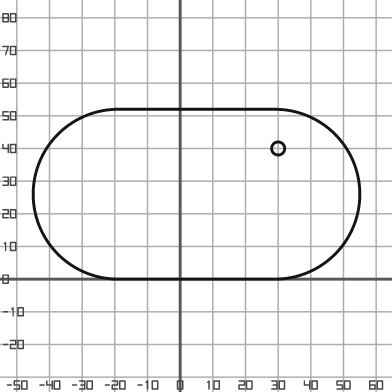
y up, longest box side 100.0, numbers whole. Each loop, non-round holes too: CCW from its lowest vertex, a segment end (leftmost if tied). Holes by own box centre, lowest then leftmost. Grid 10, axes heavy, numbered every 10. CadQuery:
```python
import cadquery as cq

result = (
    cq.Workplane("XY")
    .moveTo(-19.0, 0.0)
    .lineTo(29.0, 0.0)
    .threePointArc((55.0, 26.0), (29.0, 52.0))
    .lineTo(-19.0, 52.0)
    .threePointArc((-45.0, 26.0), (-19.0, 0.0))
    .close()
    .moveTo(30.0, 40.0)
    .circle(2.0)
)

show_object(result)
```